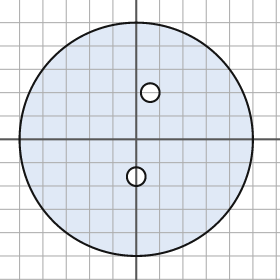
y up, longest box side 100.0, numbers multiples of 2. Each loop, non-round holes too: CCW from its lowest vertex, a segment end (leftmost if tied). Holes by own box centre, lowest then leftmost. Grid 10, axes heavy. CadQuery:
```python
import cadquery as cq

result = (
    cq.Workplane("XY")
    .moveTo(0.0, 0.0)
    .circle(50.0)
    .moveTo(0.0, -16.0)
    .circle(4.0)
    .moveTo(6.0, 20.0)
    .circle(4.0)
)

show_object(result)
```